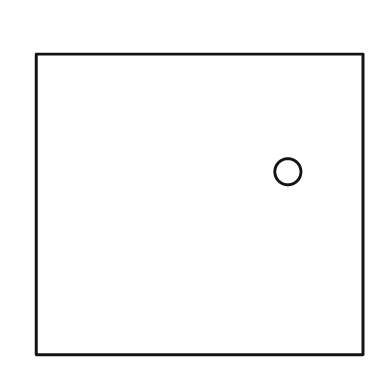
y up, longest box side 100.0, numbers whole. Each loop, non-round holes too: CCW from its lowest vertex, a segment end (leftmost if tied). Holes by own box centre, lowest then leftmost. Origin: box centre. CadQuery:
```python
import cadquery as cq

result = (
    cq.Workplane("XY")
    .moveTo(-50.0, -46.0)
    .lineTo(50.0, -46.0)
    .lineTo(50.0, 46.0)
    .lineTo(-50.0, 46.0)
    .close()
    .moveTo(27.0, 10.0)
    .circle(4.0)
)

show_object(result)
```